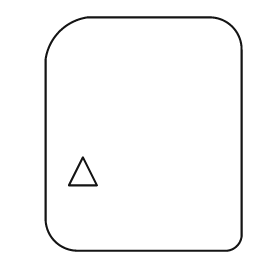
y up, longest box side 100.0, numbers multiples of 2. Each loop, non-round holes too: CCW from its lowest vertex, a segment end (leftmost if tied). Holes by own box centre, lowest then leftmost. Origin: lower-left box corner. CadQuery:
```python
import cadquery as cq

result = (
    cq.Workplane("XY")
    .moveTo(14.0, 0.0)
    .lineTo(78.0, 0.0)
    .threePointArc((82.0, 2.0), (84.0, 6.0))
    .lineTo(84.0, 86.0)
    .threePointArc((80.0, 96.0), (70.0, 100.0))
    .lineTo(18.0, 100.0)
    .threePointArc((6.0, 94.0), (0.0, 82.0))
    .lineTo(0.0, 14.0)
    .threePointArc((4.0, 4.0), (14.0, 0.0))
    .close()
    .moveTo(10.0, 28.0)
    .lineTo(22.0, 28.0)
    .lineTo(16.0, 40.0)
    .close()
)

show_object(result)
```